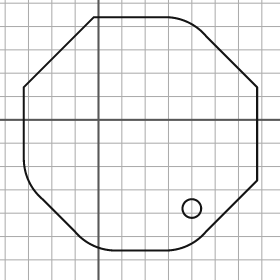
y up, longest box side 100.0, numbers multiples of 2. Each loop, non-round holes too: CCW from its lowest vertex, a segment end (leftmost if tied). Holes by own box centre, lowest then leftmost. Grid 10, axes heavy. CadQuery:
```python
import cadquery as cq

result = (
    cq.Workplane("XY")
    .moveTo(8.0, -56.0)
    .lineTo(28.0, -56.0)
    .threePointArc((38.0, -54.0), (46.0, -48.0))
    .lineTo(68.0, -26.0)
    .lineTo(68.0, 14.0)
    .lineTo(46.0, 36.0)
    .threePointArc((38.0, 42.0), (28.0, 44.0))
    .lineTo(-2.0, 44.0)
    .lineTo(-32.0, 14.0)
    .lineTo(-32.0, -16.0)
    .threePointArc((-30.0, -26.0), (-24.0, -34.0))
    .lineTo(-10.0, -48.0)
    .threePointArc((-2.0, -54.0), (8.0, -56.0))
    .close()
    .moveTo(40.0, -38.0)
    .circle(4.0)
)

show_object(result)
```